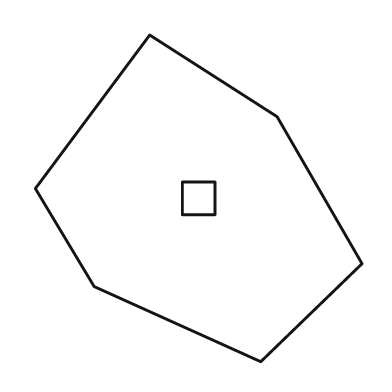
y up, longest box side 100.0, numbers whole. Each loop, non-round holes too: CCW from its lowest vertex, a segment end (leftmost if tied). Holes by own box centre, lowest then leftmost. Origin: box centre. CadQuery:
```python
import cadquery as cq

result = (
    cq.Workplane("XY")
    .moveTo(19.0, -50.0)
    .lineTo(50.0, -20.0)
    .lineTo(24.0, 25.0)
    .lineTo(-15.0, 50.0)
    .lineTo(-50.0, 3.0)
    .lineTo(-32.0, -27.0)
    .close()
    .moveTo(-5.0, -5.0)
    .lineTo(5.0, -5.0)
    .lineTo(5.0, 5.0)
    .lineTo(-5.0, 5.0)
    .close()
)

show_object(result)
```